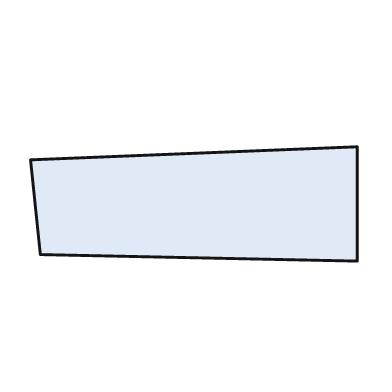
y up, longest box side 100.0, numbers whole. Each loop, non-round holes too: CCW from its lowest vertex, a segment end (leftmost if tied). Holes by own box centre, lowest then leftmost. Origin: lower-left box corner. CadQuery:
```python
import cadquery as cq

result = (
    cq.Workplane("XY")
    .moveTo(100.0, 0.0)
    .lineTo(100.0, 35.0)
    .lineTo(0.0, 31.0)
    .lineTo(3.0, 2.0)
    .close()
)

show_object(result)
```